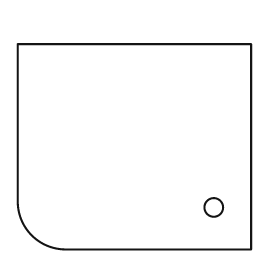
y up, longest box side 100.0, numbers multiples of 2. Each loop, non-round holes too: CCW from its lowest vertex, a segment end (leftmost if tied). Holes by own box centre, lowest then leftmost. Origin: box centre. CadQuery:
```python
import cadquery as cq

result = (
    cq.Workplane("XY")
    .moveTo(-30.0, -44.0)
    .lineTo(50.0, -44.0)
    .lineTo(50.0, 44.0)
    .lineTo(-50.0, 44.0)
    .lineTo(-50.0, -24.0)
    .threePointArc((-44.0, -38.0), (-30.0, -44.0))
    .close()
    .moveTo(34.0, -26.0)
    .circle(4.0)
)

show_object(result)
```